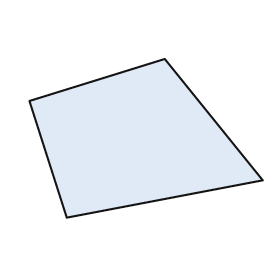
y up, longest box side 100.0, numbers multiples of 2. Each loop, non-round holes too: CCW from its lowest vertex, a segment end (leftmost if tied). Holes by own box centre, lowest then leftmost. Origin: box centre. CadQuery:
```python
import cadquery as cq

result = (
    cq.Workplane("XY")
    .moveTo(-34.0, -34.0)
    .lineTo(50.0, -18.0)
    .lineTo(8.0, 34.0)
    .lineTo(-50.0, 16.0)
    .close()
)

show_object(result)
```